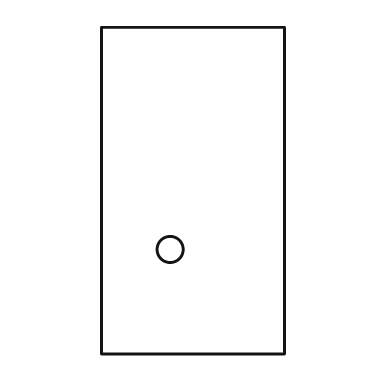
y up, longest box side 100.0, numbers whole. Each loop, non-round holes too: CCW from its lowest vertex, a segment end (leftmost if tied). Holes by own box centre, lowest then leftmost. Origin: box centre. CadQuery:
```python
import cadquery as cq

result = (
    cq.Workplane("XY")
    .moveTo(-28.0, -50.0)
    .lineTo(28.0, -50.0)
    .lineTo(28.0, 50.0)
    .lineTo(-28.0, 50.0)
    .close()
    .moveTo(-7.0, -18.0)
    .circle(4.0)
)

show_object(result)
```